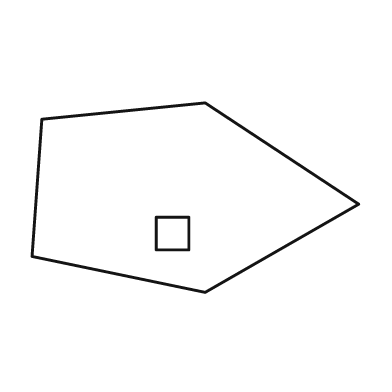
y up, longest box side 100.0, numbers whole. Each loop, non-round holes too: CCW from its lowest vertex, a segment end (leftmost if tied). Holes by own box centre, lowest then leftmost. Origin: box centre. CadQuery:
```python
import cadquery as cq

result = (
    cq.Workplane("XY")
    .moveTo(3.0, -29.0)
    .lineTo(50.0, -2.0)
    .lineTo(3.0, 29.0)
    .lineTo(-47.0, 24.0)
    .lineTo(-50.0, -18.0)
    .close()
    .moveTo(-12.0, -16.0)
    .lineTo(-2.0, -16.0)
    .lineTo(-2.0, -6.0)
    .lineTo(-12.0, -6.0)
    .close()
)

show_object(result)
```